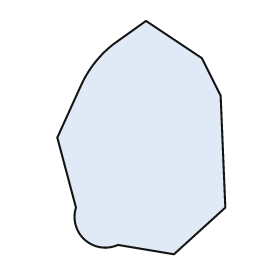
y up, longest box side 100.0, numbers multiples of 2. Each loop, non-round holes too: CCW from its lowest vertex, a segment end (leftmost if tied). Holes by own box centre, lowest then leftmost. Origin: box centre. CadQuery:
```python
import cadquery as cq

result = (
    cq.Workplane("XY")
    .moveTo(14.0, -50.0)
    .lineTo(36.0, -30.0)
    .lineTo(34.0, 18.0)
    .lineTo(26.0, 34.0)
    .lineTo(2.0, 50.0)
    .lineTo(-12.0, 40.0)
    .threePointArc((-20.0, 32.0), (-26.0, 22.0))
    .lineTo(-36.0, 0.0)
    .lineTo(-28.0, -30.0)
    .threePointArc((-24.0, -44.0), (-10.0, -46.0))
    .close()
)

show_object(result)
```